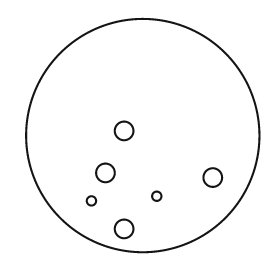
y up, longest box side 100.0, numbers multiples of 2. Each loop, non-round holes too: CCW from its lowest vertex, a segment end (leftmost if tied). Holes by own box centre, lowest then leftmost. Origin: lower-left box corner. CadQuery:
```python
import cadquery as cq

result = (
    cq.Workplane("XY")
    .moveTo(50.0, 50.0)
    .circle(50.0)
    .moveTo(42.0, 10.0)
    .circle(4.0)
    .moveTo(28.0, 22.0)
    .circle(2.0)
    .moveTo(56.0, 24.0)
    .circle(2.0)
    .moveTo(80.0, 32.0)
    .circle(4.0)
    .moveTo(34.0, 34.0)
    .circle(4.0)
    .moveTo(42.0, 52.0)
    .circle(4.0)
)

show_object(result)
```